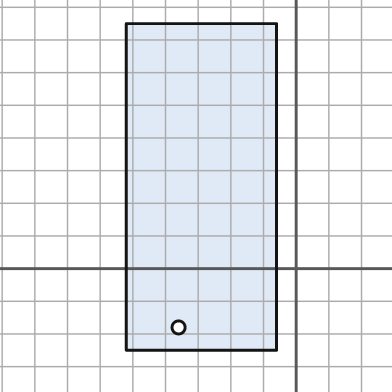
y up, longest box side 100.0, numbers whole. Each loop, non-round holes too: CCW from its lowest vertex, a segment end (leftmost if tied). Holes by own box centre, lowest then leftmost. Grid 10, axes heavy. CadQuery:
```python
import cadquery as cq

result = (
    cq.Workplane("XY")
    .moveTo(-52.0, -25.0)
    .lineTo(-6.0, -25.0)
    .lineTo(-6.0, 75.0)
    .lineTo(-52.0, 75.0)
    .close()
    .moveTo(-36.0, -18.0)
    .circle(2.0)
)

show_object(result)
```